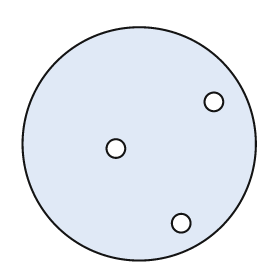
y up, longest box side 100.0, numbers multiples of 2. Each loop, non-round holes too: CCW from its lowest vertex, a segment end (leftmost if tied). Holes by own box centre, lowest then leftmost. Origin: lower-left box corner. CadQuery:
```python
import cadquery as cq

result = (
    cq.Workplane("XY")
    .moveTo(50.0, 50.0)
    .circle(50.0)
    .moveTo(68.0, 16.0)
    .circle(4.0)
    .moveTo(40.0, 48.0)
    .circle(4.0)
    .moveTo(82.0, 68.0)
    .circle(4.0)
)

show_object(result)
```